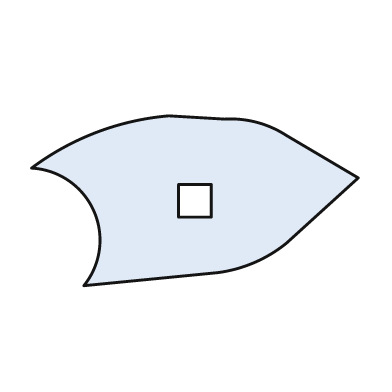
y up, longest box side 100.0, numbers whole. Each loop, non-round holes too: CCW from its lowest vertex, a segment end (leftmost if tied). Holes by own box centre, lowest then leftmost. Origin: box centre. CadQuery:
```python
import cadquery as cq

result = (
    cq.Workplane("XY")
    .moveTo(-34.0, -26.0)
    .lineTo(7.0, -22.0)
    .threePointArc((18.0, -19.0), (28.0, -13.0))
    .lineTo(50.0, 7.0)
    .lineTo(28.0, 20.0)
    .threePointArc((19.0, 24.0), (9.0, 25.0))
    .lineTo(-8.0, 26.0)
    .threePointArc((-30.0, 21.0), (-50.0, 10.0))
    .threePointArc((-31.0, -3.0), (-34.0, -26.0))
    .close()
    .moveTo(-5.0, -5.0)
    .lineTo(5.0, -5.0)
    .lineTo(5.0, 5.0)
    .lineTo(-5.0, 5.0)
    .close()
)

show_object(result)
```